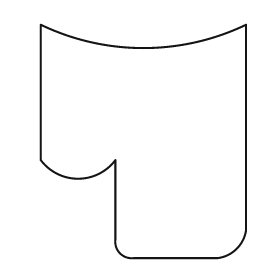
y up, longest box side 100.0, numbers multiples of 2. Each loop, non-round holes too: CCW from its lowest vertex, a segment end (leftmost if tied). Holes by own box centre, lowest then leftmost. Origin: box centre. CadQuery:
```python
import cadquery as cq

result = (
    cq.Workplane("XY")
    .moveTo(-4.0, -50.0)
    .lineTo(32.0, -50.0)
    .threePointArc((40.0, -46.0), (44.0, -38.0))
    .lineTo(44.0, 50.0)
    .threePointArc((0.0, 40.0), (-44.0, 50.0))
    .lineTo(-44.0, -8.0)
    .threePointArc((-28.0, -16.0), (-12.0, -8.0))
    .lineTo(-12.0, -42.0)
    .threePointArc((-10.0, -48.0), (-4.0, -50.0))
    .close()
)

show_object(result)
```